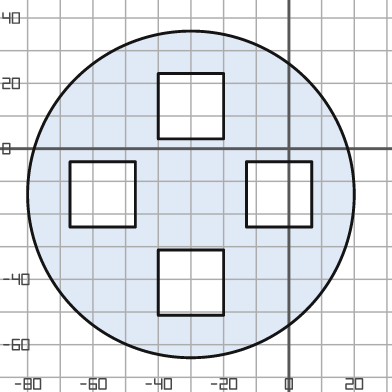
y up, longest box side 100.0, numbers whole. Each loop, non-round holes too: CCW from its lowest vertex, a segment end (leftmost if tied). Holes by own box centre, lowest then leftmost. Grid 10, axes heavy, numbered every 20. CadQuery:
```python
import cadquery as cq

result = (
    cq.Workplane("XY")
    .moveTo(-30.0, -14.0)
    .circle(50.0)
    .moveTo(-40.0, -51.0)
    .lineTo(-20.0, -51.0)
    .lineTo(-20.0, -31.0)
    .lineTo(-40.0, -31.0)
    .close()
    .moveTo(-67.0, -24.0)
    .lineTo(-47.0, -24.0)
    .lineTo(-47.0, -4.0)
    .lineTo(-67.0, -4.0)
    .close()
    .moveTo(-13.0, -24.0)
    .lineTo(7.0, -24.0)
    .lineTo(7.0, -4.0)
    .lineTo(-13.0, -4.0)
    .close()
    .moveTo(-40.0, 3.0)
    .lineTo(-20.0, 3.0)
    .lineTo(-20.0, 23.0)
    .lineTo(-40.0, 23.0)
    .close()
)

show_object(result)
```